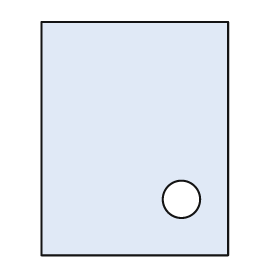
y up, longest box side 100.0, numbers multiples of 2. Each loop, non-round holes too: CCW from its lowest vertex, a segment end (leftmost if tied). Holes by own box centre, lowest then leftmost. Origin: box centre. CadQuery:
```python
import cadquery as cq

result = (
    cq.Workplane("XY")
    .moveTo(-40.0, -50.0)
    .lineTo(40.0, -50.0)
    .lineTo(40.0, 50.0)
    .lineTo(-40.0, 50.0)
    .close()
    .moveTo(20.0, -26.0)
    .circle(8.0)
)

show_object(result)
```